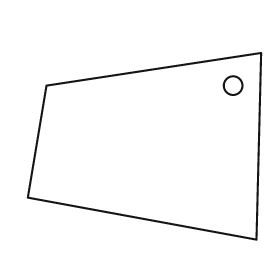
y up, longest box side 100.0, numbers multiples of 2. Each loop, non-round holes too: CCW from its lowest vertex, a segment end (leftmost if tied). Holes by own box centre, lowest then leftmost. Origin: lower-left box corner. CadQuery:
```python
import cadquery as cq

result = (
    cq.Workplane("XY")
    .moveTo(98.0, 0.0)
    .lineTo(100.0, 80.0)
    .lineTo(8.0, 66.0)
    .lineTo(0.0, 18.0)
    .close()
    .moveTo(88.0, 66.0)
    .circle(4.0)
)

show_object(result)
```